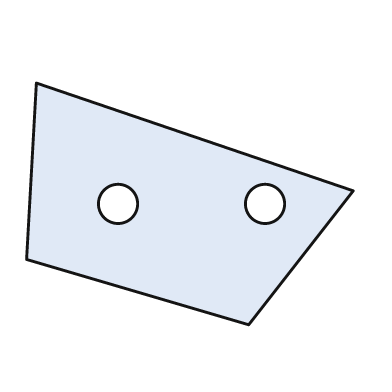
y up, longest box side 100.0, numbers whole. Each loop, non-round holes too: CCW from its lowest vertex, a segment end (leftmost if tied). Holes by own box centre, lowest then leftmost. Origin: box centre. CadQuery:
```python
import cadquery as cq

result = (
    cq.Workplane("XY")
    .moveTo(18.0, -37.0)
    .lineTo(50.0, 4.0)
    .lineTo(-47.0, 37.0)
    .lineTo(-50.0, -17.0)
    .close()
    .moveTo(-22.0, 0.0)
    .circle(6.0)
    .moveTo(23.0, 0.0)
    .circle(6.0)
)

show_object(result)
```